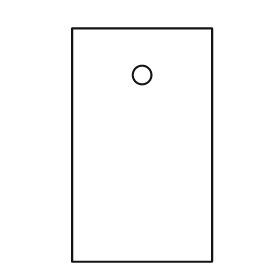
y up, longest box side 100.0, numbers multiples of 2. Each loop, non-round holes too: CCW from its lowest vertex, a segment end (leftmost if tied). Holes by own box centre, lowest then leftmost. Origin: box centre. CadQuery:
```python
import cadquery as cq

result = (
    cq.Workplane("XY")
    .moveTo(-30.0, -50.0)
    .lineTo(30.0, -50.0)
    .lineTo(30.0, 50.0)
    .lineTo(-30.0, 50.0)
    .close()
    .moveTo(0.0, 30.0)
    .circle(4.0)
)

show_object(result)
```